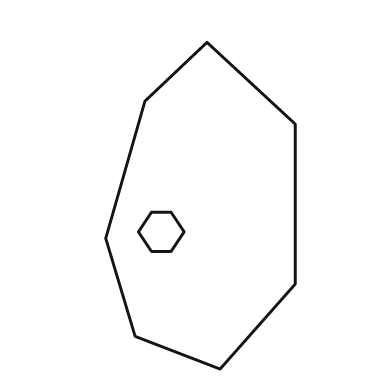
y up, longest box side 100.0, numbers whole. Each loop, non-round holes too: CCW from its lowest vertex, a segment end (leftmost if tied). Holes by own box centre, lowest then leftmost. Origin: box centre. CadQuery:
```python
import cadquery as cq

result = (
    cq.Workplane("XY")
    .moveTo(6.0, -50.0)
    .lineTo(29.0, -24.0)
    .lineTo(29.0, 25.0)
    .lineTo(2.0, 50.0)
    .lineTo(-17.0, 32.0)
    .lineTo(-29.0, -10.0)
    .lineTo(-20.0, -40.0)
    .close()
    .moveTo(-15.0, -14.0)
    .lineTo(-9.0, -14.0)
    .lineTo(-5.0, -8.0)
    .lineTo(-9.0, -2.0)
    .lineTo(-15.0, -2.0)
    .lineTo(-19.0, -8.0)
    .close()
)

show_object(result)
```